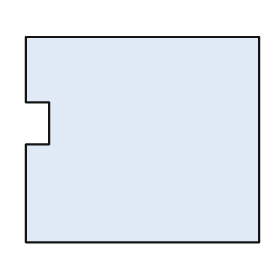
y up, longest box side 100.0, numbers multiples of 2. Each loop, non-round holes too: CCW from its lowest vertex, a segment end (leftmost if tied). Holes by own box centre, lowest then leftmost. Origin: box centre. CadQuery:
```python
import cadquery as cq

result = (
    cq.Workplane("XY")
    .moveTo(-50.0, -44.0)
    .lineTo(50.0, -44.0)
    .lineTo(50.0, 44.0)
    .lineTo(-50.0, 44.0)
    .lineTo(-50.0, 16.0)
    .lineTo(-40.0, 16.0)
    .lineTo(-40.0, -2.0)
    .lineTo(-50.0, -2.0)
    .close()
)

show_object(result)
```